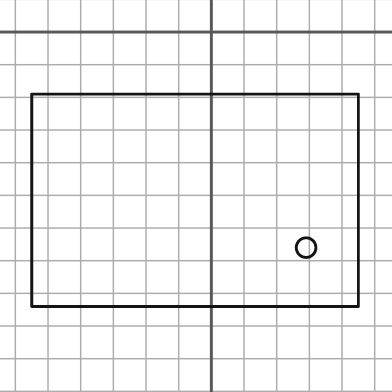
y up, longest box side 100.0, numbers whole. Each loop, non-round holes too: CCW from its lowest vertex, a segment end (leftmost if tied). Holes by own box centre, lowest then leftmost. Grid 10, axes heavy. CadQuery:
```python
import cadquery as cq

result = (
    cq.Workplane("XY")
    .moveTo(-55.0, -84.0)
    .lineTo(45.0, -84.0)
    .lineTo(45.0, -19.0)
    .lineTo(-55.0, -19.0)
    .close()
    .moveTo(29.0, -66.0)
    .circle(3.0)
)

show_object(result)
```